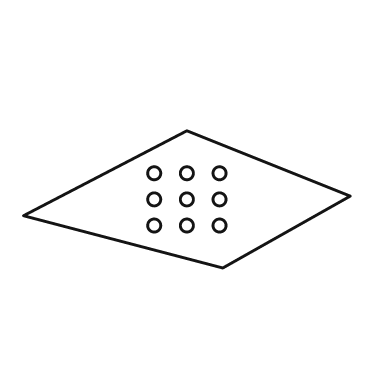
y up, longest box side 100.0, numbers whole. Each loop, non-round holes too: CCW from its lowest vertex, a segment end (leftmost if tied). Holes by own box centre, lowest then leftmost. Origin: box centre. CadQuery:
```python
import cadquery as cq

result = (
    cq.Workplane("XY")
    .moveTo(11.0, -21.0)
    .lineTo(50.0, 1.0)
    .lineTo(0.0, 21.0)
    .lineTo(-50.0, -5.0)
    .close()
    .moveTo(-10.0, -8.0)
    .circle(2.0)
    .moveTo(0.0, -8.0)
    .circle(2.0)
    .moveTo(10.0, -8.0)
    .circle(2.0)
    .moveTo(-10.0, 0.0)
    .circle(2.0)
    .moveTo(0.0, 0.0)
    .circle(2.0)
    .moveTo(10.0, 0.0)
    .circle(2.0)
    .moveTo(-10.0, 8.0)
    .circle(2.0)
    .moveTo(0.0, 8.0)
    .circle(2.0)
    .moveTo(10.0, 8.0)
    .circle(2.0)
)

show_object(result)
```